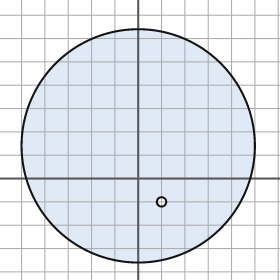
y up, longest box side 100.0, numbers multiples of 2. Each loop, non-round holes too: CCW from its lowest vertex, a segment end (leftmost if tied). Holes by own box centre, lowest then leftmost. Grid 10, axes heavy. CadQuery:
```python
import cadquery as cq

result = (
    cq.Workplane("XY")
    .moveTo(0.0, 14.0)
    .circle(50.0)
    .moveTo(10.0, -10.0)
    .circle(2.0)
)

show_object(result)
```